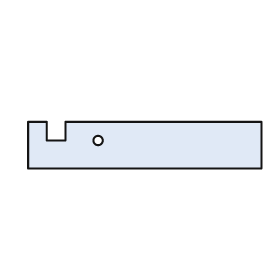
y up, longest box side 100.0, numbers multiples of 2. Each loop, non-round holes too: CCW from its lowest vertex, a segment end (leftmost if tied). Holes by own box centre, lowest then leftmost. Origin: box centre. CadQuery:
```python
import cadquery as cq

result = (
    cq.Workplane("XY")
    .moveTo(-50.0, -10.0)
    .lineTo(50.0, -10.0)
    .lineTo(50.0, 10.0)
    .lineTo(-34.0, 10.0)
    .lineTo(-34.0, 2.0)
    .lineTo(-42.0, 2.0)
    .lineTo(-42.0, 10.0)
    .lineTo(-50.0, 10.0)
    .close()
    .moveTo(-20.0, 2.0)
    .circle(2.0)
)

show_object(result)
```